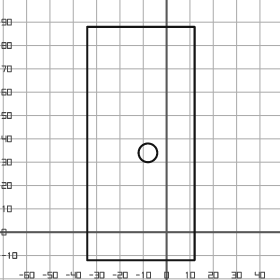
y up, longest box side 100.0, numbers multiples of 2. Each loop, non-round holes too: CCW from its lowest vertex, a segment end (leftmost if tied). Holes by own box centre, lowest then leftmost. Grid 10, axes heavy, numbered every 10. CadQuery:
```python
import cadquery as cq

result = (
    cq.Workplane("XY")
    .moveTo(-34.0, -12.0)
    .lineTo(12.0, -12.0)
    .lineTo(12.0, 88.0)
    .lineTo(-34.0, 88.0)
    .close()
    .moveTo(-8.0, 34.0)
    .circle(4.0)
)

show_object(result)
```